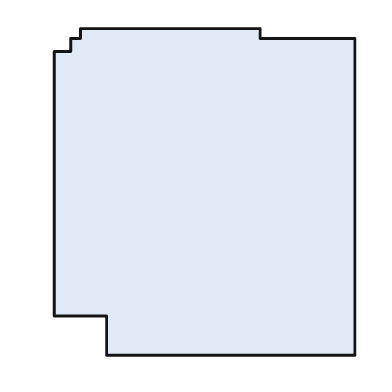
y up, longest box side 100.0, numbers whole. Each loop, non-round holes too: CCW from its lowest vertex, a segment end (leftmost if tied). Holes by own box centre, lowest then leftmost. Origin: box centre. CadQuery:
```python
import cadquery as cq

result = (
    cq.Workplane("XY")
    .moveTo(-30.0, -50.0)
    .lineTo(46.0, -50.0)
    .lineTo(46.0, 47.0)
    .lineTo(17.0, 47.0)
    .lineTo(17.0, 50.0)
    .lineTo(-38.0, 50.0)
    .lineTo(-38.0, 47.0)
    .lineTo(-41.0, 47.0)
    .lineTo(-41.0, 43.0)
    .lineTo(-46.0, 43.0)
    .lineTo(-46.0, -38.0)
    .lineTo(-30.0, -38.0)
    .close()
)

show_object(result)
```